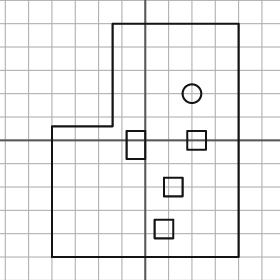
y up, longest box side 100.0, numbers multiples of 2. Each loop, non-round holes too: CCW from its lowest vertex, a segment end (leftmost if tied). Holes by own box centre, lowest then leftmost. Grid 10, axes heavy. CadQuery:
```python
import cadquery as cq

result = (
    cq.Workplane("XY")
    .moveTo(-40.0, -50.0)
    .lineTo(40.0, -50.0)
    .lineTo(40.0, 50.0)
    .lineTo(-14.0, 50.0)
    .lineTo(-14.0, 6.0)
    .lineTo(-40.0, 6.0)
    .close()
    .moveTo(4.0, -42.0)
    .lineTo(12.0, -42.0)
    .lineTo(12.0, -34.0)
    .lineTo(4.0, -34.0)
    .close()
    .moveTo(8.0, -24.0)
    .lineTo(16.0, -24.0)
    .lineTo(16.0, -16.0)
    .lineTo(8.0, -16.0)
    .close()
    .moveTo(-8.0, -8.0)
    .lineTo(0.0, -8.0)
    .lineTo(0.0, 4.0)
    .lineTo(-8.0, 4.0)
    .close()
    .moveTo(18.0, -4.0)
    .lineTo(26.0, -4.0)
    .lineTo(26.0, 4.0)
    .lineTo(18.0, 4.0)
    .close()
    .moveTo(20.0, 20.0)
    .circle(4.0)
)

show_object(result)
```